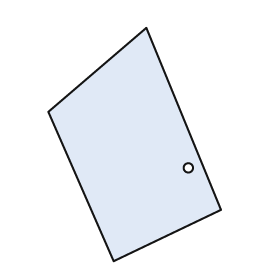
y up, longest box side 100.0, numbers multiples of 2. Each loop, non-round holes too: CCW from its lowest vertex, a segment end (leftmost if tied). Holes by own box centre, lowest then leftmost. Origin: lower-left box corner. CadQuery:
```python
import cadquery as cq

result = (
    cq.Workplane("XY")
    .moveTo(28.0, 0.0)
    .lineTo(74.0, 22.0)
    .lineTo(42.0, 100.0)
    .lineTo(0.0, 64.0)
    .close()
    .moveTo(60.0, 40.0)
    .circle(2.0)
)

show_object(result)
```